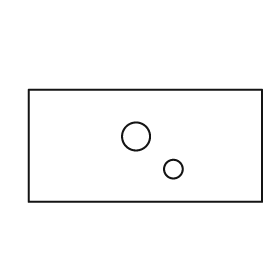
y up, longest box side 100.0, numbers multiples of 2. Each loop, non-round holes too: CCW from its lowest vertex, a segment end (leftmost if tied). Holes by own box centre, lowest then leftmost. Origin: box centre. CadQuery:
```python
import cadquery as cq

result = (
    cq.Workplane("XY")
    .moveTo(-50.0, -24.0)
    .lineTo(50.0, -24.0)
    .lineTo(50.0, 24.0)
    .lineTo(-50.0, 24.0)
    .close()
    .moveTo(12.0, -10.0)
    .circle(4.0)
    .moveTo(-4.0, 4.0)
    .circle(6.0)
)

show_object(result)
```